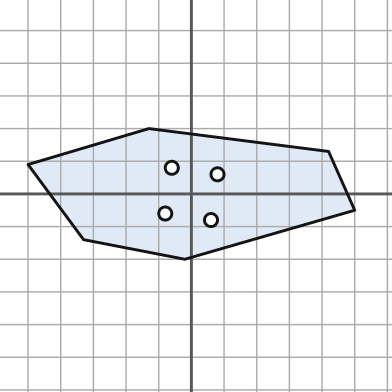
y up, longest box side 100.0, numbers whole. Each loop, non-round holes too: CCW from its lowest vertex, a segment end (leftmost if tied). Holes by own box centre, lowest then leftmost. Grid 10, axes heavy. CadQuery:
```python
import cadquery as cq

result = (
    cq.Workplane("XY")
    .moveTo(-2.0, -20.0)
    .lineTo(50.0, -5.0)
    .lineTo(42.0, 13.0)
    .lineTo(-13.0, 20.0)
    .lineTo(-50.0, 9.0)
    .lineTo(-33.0, -14.0)
    .close()
    .moveTo(6.0, -8.0)
    .circle(2.0)
    .moveTo(-8.0, -6.0)
    .circle(2.0)
    .moveTo(8.0, 6.0)
    .circle(2.0)
    .moveTo(-6.0, 8.0)
    .circle(2.0)
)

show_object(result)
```